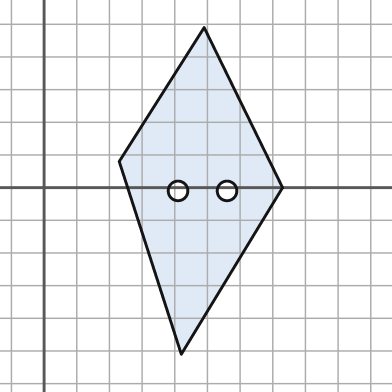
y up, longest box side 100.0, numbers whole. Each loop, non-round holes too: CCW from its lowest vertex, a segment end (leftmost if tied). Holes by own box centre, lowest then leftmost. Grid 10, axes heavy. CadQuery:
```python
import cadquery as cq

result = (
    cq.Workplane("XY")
    .moveTo(42.0, -51.0)
    .lineTo(73.0, 0.0)
    .lineTo(49.0, 49.0)
    .lineTo(23.0, 8.0)
    .close()
    .moveTo(41.0, -1.0)
    .circle(3.0)
    .moveTo(56.0, -1.0)
    .circle(3.0)
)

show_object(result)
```